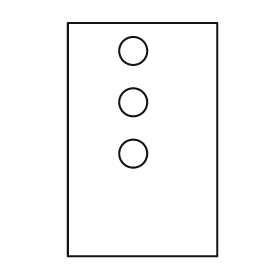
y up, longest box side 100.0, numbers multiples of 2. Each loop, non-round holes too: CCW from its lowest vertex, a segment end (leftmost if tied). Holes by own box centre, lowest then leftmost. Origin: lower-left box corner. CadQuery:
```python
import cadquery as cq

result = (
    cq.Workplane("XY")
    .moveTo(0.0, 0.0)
    .lineTo(64.0, 0.0)
    .lineTo(64.0, 100.0)
    .lineTo(0.0, 100.0)
    .close()
    .moveTo(28.0, 44.0)
    .circle(6.0)
    .moveTo(28.0, 66.0)
    .circle(6.0)
    .moveTo(28.0, 88.0)
    .circle(6.0)
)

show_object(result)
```